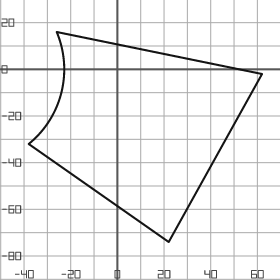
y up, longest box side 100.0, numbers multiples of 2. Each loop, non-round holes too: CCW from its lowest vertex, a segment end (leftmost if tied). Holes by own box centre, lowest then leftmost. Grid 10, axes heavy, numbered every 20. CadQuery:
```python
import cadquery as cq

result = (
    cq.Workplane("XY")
    .moveTo(22.0, -74.0)
    .lineTo(62.0, -2.0)
    .lineTo(-26.0, 16.0)
    .threePointArc((-24.0, -10.0), (-38.0, -32.0))
    .close()
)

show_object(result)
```